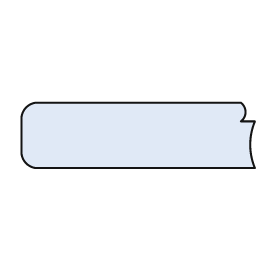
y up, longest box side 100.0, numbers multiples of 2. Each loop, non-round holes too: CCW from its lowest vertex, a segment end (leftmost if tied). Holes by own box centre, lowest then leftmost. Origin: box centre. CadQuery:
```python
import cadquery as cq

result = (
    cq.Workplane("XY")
    .moveTo(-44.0, -14.0)
    .lineTo(50.0, -14.0)
    .threePointArc((48.0, -4.0), (50.0, 6.0))
    .lineTo(44.0, 6.0)
    .threePointArc((46.0, 10.0), (44.0, 14.0))
    .lineTo(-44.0, 14.0)
    .threePointArc((-48.0, 12.0), (-50.0, 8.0))
    .lineTo(-50.0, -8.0)
    .threePointArc((-48.0, -12.0), (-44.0, -14.0))
    .close()
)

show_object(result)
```